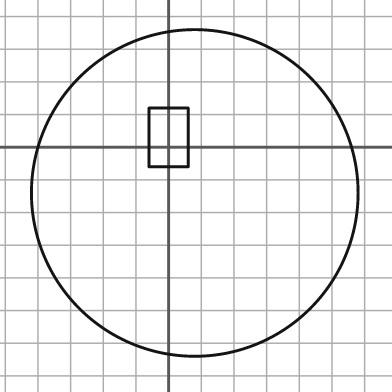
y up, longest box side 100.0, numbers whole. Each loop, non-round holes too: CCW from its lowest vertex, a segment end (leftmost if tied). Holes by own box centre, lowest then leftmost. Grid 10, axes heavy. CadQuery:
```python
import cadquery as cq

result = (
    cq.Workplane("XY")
    .moveTo(8.0, -14.0)
    .circle(50.0)
    .moveTo(-6.0, -6.0)
    .lineTo(6.0, -6.0)
    .lineTo(6.0, 12.0)
    .lineTo(-6.0, 12.0)
    .close()
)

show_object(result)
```